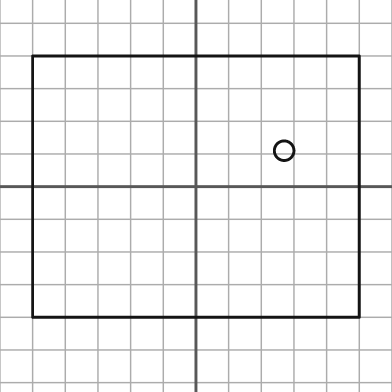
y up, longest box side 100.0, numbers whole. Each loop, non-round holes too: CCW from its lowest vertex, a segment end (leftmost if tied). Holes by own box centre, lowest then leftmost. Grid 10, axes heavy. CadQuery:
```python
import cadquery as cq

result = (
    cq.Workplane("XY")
    .moveTo(-50.0, -40.0)
    .lineTo(50.0, -40.0)
    .lineTo(50.0, 40.0)
    .lineTo(-50.0, 40.0)
    .close()
    .moveTo(27.0, 11.0)
    .circle(3.0)
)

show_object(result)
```